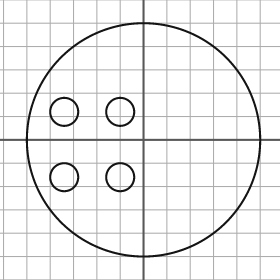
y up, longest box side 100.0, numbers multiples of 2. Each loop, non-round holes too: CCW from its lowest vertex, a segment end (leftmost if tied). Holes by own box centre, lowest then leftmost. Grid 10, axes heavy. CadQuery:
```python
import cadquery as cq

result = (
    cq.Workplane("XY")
    .moveTo(0.0, 0.0)
    .circle(50.0)
    .moveTo(-34.0, -16.0)
    .circle(6.0)
    .moveTo(-10.0, -16.0)
    .circle(6.0)
    .moveTo(-34.0, 12.0)
    .circle(6.0)
    .moveTo(-10.0, 12.0)
    .circle(6.0)
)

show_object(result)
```